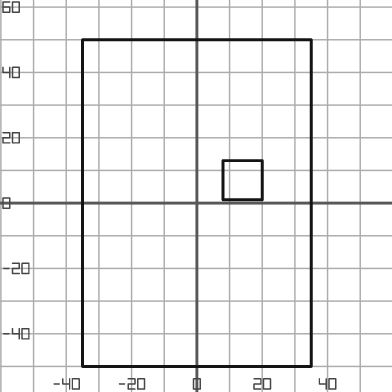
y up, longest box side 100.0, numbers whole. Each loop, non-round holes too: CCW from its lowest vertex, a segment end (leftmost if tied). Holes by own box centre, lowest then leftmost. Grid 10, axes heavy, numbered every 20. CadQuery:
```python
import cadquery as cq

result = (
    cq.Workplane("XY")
    .moveTo(-35.0, -50.0)
    .lineTo(35.0, -50.0)
    .lineTo(35.0, 50.0)
    .lineTo(-35.0, 50.0)
    .close()
    .moveTo(8.0, 1.0)
    .lineTo(20.0, 1.0)
    .lineTo(20.0, 13.0)
    .lineTo(8.0, 13.0)
    .close()
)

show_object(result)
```